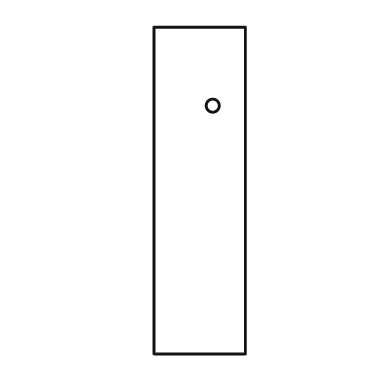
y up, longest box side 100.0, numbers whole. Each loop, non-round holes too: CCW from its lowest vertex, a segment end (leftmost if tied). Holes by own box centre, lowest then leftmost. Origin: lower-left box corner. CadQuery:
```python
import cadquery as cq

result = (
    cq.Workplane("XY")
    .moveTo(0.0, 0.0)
    .lineTo(28.0, 0.0)
    .lineTo(28.0, 100.0)
    .lineTo(0.0, 100.0)
    .close()
    .moveTo(18.0, 76.0)
    .circle(2.0)
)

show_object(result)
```